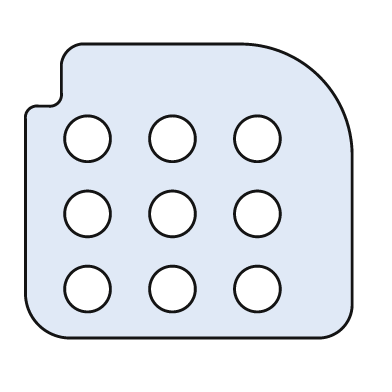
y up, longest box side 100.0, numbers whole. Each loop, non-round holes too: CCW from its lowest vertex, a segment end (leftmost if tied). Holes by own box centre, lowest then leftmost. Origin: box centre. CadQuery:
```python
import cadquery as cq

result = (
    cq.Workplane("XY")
    .moveTo(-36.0, -45.0)
    .lineTo(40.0, -45.0)
    .threePointArc((47.0, -42.0), (50.0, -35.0))
    .lineTo(50.0, 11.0)
    .threePointArc((40.0, 35.0), (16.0, 45.0))
    .lineTo(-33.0, 45.0)
    .threePointArc((-37.0, 43.0), (-39.0, 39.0))
    .lineTo(-39.0, 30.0)
    .threePointArc((-40.0, 27.0), (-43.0, 26.0))
    .lineTo(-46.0, 26.0)
    .threePointArc((-49.0, 25.0), (-50.0, 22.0))
    .lineTo(-50.0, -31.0)
    .threePointArc((-46.0, -41.0), (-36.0, -45.0))
    .close()
    .moveTo(-31.0, -30.0)
    .circle(7.0)
    .moveTo(-5.0, -30.0)
    .circle(7.0)
    .moveTo(21.0, -30.0)
    .circle(7.0)
    .moveTo(-31.0, -7.0)
    .circle(7.0)
    .moveTo(-5.0, -7.0)
    .circle(7.0)
    .moveTo(21.0, -7.0)
    .circle(7.0)
    .moveTo(-31.0, 16.0)
    .circle(7.0)
    .moveTo(-5.0, 16.0)
    .circle(7.0)
    .moveTo(21.0, 16.0)
    .circle(7.0)
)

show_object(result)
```